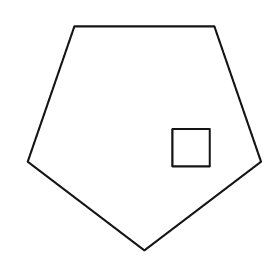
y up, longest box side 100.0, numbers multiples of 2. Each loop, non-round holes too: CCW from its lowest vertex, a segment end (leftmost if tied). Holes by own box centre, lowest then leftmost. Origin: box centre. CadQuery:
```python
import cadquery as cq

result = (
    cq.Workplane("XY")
    .moveTo(0.0, -48.0)
    .lineTo(50.0, -10.0)
    .lineTo(30.0, 48.0)
    .lineTo(-30.0, 48.0)
    .lineTo(-50.0, -10.0)
    .close()
    .moveTo(12.0, -12.0)
    .lineTo(28.0, -12.0)
    .lineTo(28.0, 4.0)
    .lineTo(12.0, 4.0)
    .close()
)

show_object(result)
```